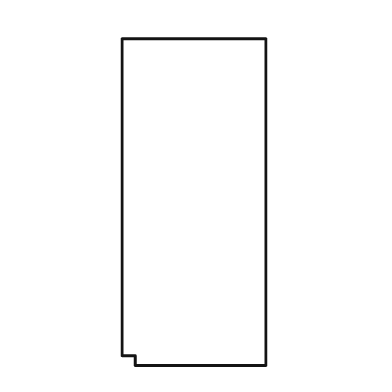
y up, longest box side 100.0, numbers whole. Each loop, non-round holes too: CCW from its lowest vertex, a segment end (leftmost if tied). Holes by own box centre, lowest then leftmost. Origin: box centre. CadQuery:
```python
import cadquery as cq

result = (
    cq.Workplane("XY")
    .moveTo(-18.0, -50.0)
    .lineTo(22.0, -50.0)
    .lineTo(22.0, 50.0)
    .lineTo(-22.0, 50.0)
    .lineTo(-22.0, -47.0)
    .lineTo(-18.0, -47.0)
    .close()
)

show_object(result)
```